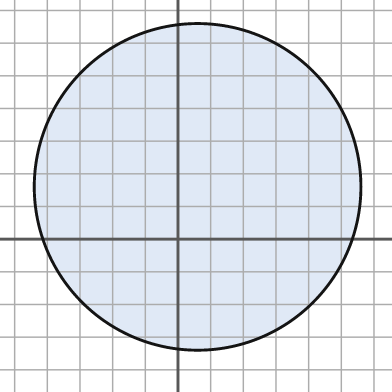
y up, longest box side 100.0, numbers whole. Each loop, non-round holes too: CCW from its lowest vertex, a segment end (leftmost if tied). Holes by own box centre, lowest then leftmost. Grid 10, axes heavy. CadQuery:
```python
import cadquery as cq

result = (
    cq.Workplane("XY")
    .moveTo(6.0, 16.0)
    .circle(50.0)
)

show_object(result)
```